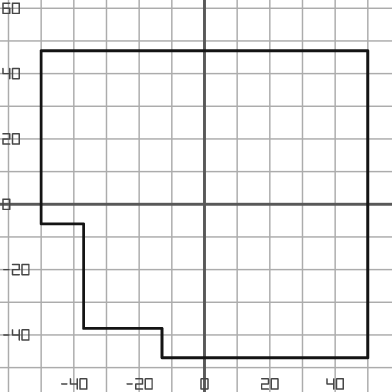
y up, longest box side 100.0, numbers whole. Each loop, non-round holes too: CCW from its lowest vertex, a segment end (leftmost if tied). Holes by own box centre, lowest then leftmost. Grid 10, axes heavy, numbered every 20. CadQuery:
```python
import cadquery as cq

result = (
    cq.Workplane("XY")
    .moveTo(-13.0, -47.0)
    .lineTo(50.0, -47.0)
    .lineTo(50.0, 47.0)
    .lineTo(-50.0, 47.0)
    .lineTo(-50.0, -6.0)
    .lineTo(-37.0, -6.0)
    .lineTo(-37.0, -38.0)
    .lineTo(-13.0, -38.0)
    .close()
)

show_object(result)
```